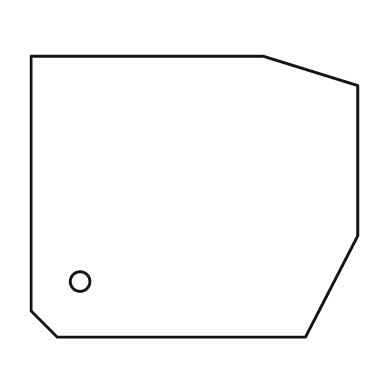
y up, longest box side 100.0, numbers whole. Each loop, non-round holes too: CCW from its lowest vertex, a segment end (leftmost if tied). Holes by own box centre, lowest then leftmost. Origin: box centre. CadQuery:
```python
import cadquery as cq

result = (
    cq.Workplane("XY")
    .moveTo(-42.0, -43.0)
    .lineTo(34.0, -43.0)
    .lineTo(50.0, -12.0)
    .lineTo(50.0, 34.0)
    .lineTo(21.0, 43.0)
    .lineTo(-50.0, 43.0)
    .lineTo(-50.0, -35.0)
    .close()
    .moveTo(-35.0, -26.0)
    .circle(3.0)
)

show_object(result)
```